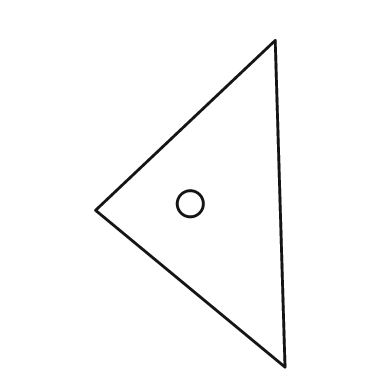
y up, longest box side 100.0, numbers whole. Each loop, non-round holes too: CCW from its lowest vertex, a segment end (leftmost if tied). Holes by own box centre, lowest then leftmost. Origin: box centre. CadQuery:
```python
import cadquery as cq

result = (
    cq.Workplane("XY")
    .moveTo(29.0, -50.0)
    .lineTo(26.0, 50.0)
    .lineTo(-29.0, -2.0)
    .close()
    .moveTo(0.0, 0.0)
    .circle(4.0)
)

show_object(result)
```